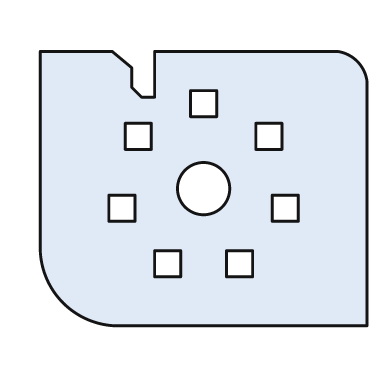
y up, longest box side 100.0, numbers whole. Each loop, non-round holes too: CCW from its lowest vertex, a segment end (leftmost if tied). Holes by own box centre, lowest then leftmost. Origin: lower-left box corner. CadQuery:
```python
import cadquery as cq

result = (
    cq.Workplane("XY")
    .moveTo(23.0, 0.0)
    .lineTo(100.0, 0.0)
    .lineTo(100.0, 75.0)
    .threePointArc((97.0, 81.0), (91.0, 84.0))
    .lineTo(35.0, 84.0)
    .lineTo(35.0, 70.0)
    .lineTo(31.0, 70.0)
    .lineTo(28.0, 73.0)
    .lineTo(28.0, 79.0)
    .lineTo(22.0, 84.0)
    .lineTo(0.0, 84.0)
    .lineTo(0.0, 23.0)
    .threePointArc((7.0, 7.0), (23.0, 0.0))
    .close()
    .moveTo(35.0, 15.0)
    .lineTo(43.0, 15.0)
    .lineTo(43.0, 23.0)
    .lineTo(35.0, 23.0)
    .close()
    .moveTo(57.0, 15.0)
    .lineTo(65.0, 15.0)
    .lineTo(65.0, 23.0)
    .lineTo(57.0, 23.0)
    .close()
    .moveTo(21.0, 32.0)
    .lineTo(29.0, 32.0)
    .lineTo(29.0, 40.0)
    .lineTo(21.0, 40.0)
    .close()
    .moveTo(71.0, 32.0)
    .lineTo(79.0, 32.0)
    .lineTo(79.0, 40.0)
    .lineTo(71.0, 40.0)
    .close()
    .moveTo(50.0, 42.0)
    .circle(8.0)
    .moveTo(26.0, 54.0)
    .lineTo(34.0, 54.0)
    .lineTo(34.0, 62.0)
    .lineTo(26.0, 62.0)
    .close()
    .moveTo(66.0, 54.0)
    .lineTo(74.0, 54.0)
    .lineTo(74.0, 62.0)
    .lineTo(66.0, 62.0)
    .close()
    .moveTo(46.0, 64.0)
    .lineTo(54.0, 64.0)
    .lineTo(54.0, 72.0)
    .lineTo(46.0, 72.0)
    .close()
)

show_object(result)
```